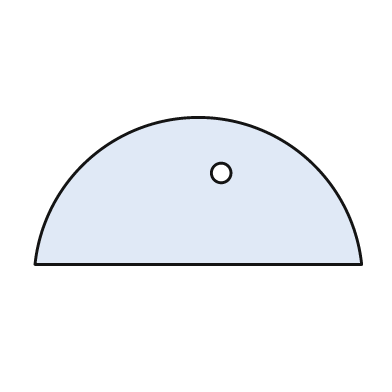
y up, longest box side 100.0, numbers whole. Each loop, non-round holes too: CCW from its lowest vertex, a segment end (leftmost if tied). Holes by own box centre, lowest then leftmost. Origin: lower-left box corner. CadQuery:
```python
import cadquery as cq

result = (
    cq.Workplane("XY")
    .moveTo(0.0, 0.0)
    .lineTo(100.0, 0.0)
    .threePointArc((50.0, 45.0), (0.0, 0.0))
    .close()
    .moveTo(57.0, 28.0)
    .circle(3.0)
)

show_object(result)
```